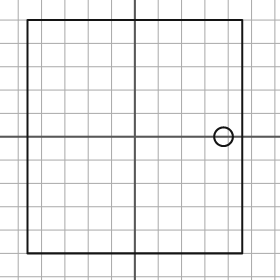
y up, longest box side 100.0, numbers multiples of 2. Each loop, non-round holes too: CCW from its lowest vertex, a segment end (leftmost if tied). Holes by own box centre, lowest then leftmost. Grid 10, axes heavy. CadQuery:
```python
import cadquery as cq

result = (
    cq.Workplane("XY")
    .moveTo(-46.0, -50.0)
    .lineTo(46.0, -50.0)
    .lineTo(46.0, 50.0)
    .lineTo(-46.0, 50.0)
    .close()
    .moveTo(38.0, 0.0)
    .circle(4.0)
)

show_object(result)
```